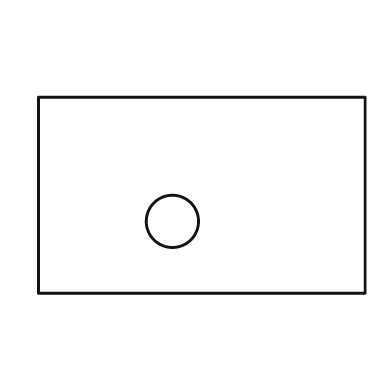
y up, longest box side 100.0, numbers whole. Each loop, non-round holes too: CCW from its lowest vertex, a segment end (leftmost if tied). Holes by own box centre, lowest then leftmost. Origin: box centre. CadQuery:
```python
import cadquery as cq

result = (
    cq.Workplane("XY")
    .moveTo(-50.0, -30.0)
    .lineTo(50.0, -30.0)
    .lineTo(50.0, 30.0)
    .lineTo(-50.0, 30.0)
    .close()
    .moveTo(-9.0, -8.0)
    .circle(8.0)
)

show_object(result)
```